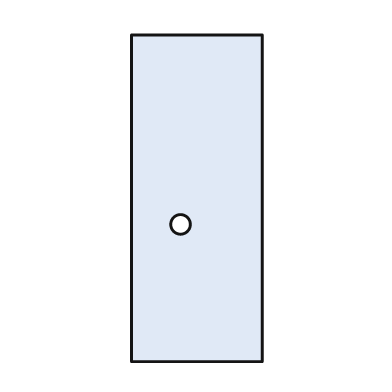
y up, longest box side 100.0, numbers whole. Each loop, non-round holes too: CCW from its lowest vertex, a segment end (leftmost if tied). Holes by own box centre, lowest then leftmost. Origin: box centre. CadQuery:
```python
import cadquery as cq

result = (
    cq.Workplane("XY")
    .moveTo(-20.0, -50.0)
    .lineTo(20.0, -50.0)
    .lineTo(20.0, 50.0)
    .lineTo(-20.0, 50.0)
    .close()
    .moveTo(-5.0, -8.0)
    .circle(3.0)
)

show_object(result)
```